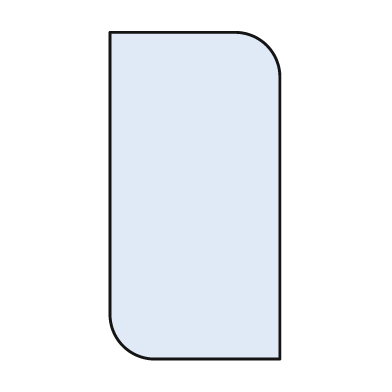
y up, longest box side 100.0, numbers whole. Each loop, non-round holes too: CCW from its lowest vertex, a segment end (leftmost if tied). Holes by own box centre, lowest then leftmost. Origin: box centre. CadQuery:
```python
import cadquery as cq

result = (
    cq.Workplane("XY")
    .moveTo(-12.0, -50.0)
    .lineTo(26.0, -50.0)
    .lineTo(26.0, 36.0)
    .threePointArc((22.0, 46.0), (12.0, 50.0))
    .lineTo(-26.0, 50.0)
    .lineTo(-26.0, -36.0)
    .threePointArc((-22.0, -46.0), (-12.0, -50.0))
    .close()
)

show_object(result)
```